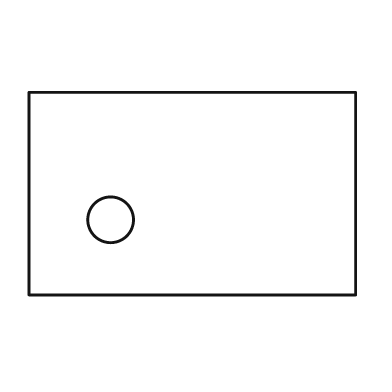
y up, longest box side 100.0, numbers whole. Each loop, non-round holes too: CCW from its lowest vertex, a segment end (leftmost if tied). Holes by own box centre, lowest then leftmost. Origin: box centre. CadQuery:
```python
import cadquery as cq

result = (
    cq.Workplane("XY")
    .moveTo(-50.0, -31.0)
    .lineTo(50.0, -31.0)
    .lineTo(50.0, 31.0)
    .lineTo(-50.0, 31.0)
    .close()
    .moveTo(-25.0, -8.0)
    .circle(7.0)
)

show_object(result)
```